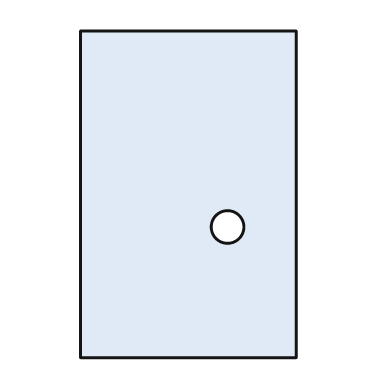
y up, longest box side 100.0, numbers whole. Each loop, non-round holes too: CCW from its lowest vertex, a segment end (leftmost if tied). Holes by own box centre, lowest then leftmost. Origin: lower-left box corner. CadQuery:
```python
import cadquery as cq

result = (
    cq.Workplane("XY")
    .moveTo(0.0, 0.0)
    .lineTo(66.0, 0.0)
    .lineTo(66.0, 100.0)
    .lineTo(0.0, 100.0)
    .close()
    .moveTo(45.0, 40.0)
    .circle(5.0)
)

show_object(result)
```